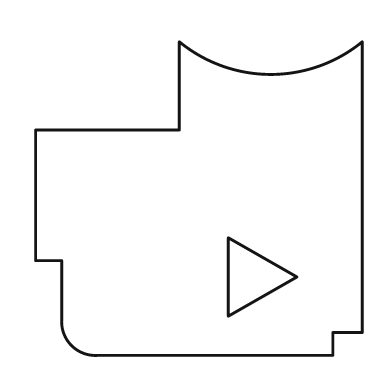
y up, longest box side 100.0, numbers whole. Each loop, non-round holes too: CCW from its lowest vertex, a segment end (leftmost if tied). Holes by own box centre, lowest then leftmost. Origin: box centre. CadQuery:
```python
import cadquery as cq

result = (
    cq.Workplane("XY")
    .moveTo(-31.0, -48.0)
    .lineTo(41.0, -48.0)
    .lineTo(41.0, -41.0)
    .lineTo(50.0, -41.0)
    .lineTo(50.0, 48.0)
    .threePointArc((22.0, 38.0), (-6.0, 48.0))
    .lineTo(-6.0, 21.0)
    .lineTo(-50.0, 21.0)
    .lineTo(-50.0, -19.0)
    .lineTo(-42.0, -19.0)
    .lineTo(-42.0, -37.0)
    .threePointArc((-39.0, -45.0), (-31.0, -48.0))
    .close()
    .moveTo(9.0, -36.0)
    .lineTo(30.0, -24.0)
    .lineTo(9.0, -12.0)
    .close()
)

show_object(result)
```